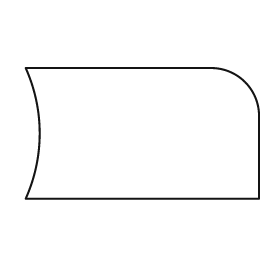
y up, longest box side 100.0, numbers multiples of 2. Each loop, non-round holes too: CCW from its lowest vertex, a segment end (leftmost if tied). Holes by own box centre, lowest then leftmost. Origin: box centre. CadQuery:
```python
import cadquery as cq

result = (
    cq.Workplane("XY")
    .moveTo(-50.0, -28.0)
    .lineTo(50.0, -28.0)
    .lineTo(50.0, 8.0)
    .threePointArc((44.0, 22.0), (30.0, 28.0))
    .lineTo(-50.0, 28.0)
    .threePointArc((-44.0, 0.0), (-50.0, -28.0))
    .close()
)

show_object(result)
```